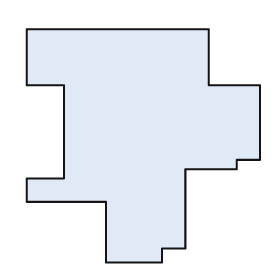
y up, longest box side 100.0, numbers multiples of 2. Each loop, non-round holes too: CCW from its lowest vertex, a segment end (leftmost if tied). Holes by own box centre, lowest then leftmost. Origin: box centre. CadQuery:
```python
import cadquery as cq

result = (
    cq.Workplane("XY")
    .moveTo(-16.0, -50.0)
    .lineTo(8.0, -50.0)
    .lineTo(8.0, -44.0)
    .lineTo(18.0, -44.0)
    .lineTo(18.0, -10.0)
    .lineTo(40.0, -10.0)
    .lineTo(40.0, -6.0)
    .lineTo(50.0, -6.0)
    .lineTo(50.0, 26.0)
    .lineTo(28.0, 26.0)
    .lineTo(28.0, 50.0)
    .lineTo(-50.0, 50.0)
    .lineTo(-50.0, 26.0)
    .lineTo(-34.0, 26.0)
    .lineTo(-34.0, -14.0)
    .lineTo(-50.0, -14.0)
    .lineTo(-50.0, -24.0)
    .lineTo(-16.0, -24.0)
    .close()
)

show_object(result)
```